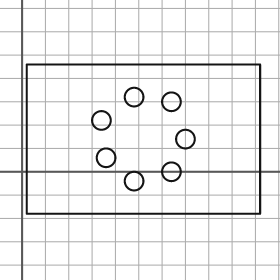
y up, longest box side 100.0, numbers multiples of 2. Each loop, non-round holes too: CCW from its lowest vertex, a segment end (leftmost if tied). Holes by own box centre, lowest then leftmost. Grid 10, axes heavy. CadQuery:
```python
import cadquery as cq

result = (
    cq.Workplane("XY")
    .moveTo(2.0, -18.0)
    .lineTo(102.0, -18.0)
    .lineTo(102.0, 46.0)
    .lineTo(2.0, 46.0)
    .close()
    .moveTo(48.0, -4.0)
    .circle(4.0)
    .moveTo(64.0, 0.0)
    .circle(4.0)
    .moveTo(36.0, 6.0)
    .circle(4.0)
    .moveTo(70.0, 14.0)
    .circle(4.0)
    .moveTo(34.0, 22.0)
    .circle(4.0)
    .moveTo(64.0, 30.0)
    .circle(4.0)
    .moveTo(48.0, 32.0)
    .circle(4.0)
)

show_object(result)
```